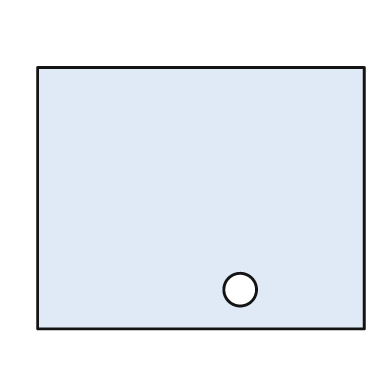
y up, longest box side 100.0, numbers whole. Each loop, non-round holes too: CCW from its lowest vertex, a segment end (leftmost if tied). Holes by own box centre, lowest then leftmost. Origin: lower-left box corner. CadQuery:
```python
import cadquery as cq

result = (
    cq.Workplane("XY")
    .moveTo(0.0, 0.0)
    .lineTo(100.0, 0.0)
    .lineTo(100.0, 80.0)
    .lineTo(0.0, 80.0)
    .close()
    .moveTo(62.0, 12.0)
    .circle(5.0)
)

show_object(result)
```